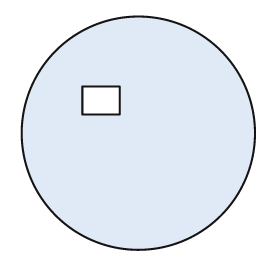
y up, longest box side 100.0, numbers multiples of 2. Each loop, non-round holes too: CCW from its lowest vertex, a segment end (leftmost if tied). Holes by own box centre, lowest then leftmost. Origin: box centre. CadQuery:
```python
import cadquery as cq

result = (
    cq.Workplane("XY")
    .moveTo(0.0, 0.0)
    .circle(50.0)
    .moveTo(-24.0, 8.0)
    .lineTo(-8.0, 8.0)
    .lineTo(-8.0, 20.0)
    .lineTo(-24.0, 20.0)
    .close()
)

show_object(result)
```